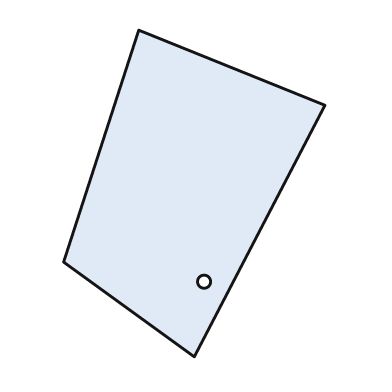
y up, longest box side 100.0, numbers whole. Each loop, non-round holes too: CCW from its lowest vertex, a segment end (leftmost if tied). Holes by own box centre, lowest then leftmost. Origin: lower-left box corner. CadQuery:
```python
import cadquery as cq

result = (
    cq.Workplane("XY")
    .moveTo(40.0, 0.0)
    .lineTo(80.0, 77.0)
    .lineTo(23.0, 100.0)
    .lineTo(0.0, 29.0)
    .close()
    .moveTo(43.0, 23.0)
    .circle(2.0)
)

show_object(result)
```